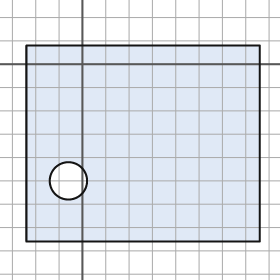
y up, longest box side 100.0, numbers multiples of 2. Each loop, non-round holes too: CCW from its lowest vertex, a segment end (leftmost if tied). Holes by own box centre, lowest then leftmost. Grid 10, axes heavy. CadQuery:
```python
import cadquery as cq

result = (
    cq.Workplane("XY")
    .moveTo(-24.0, -76.0)
    .lineTo(76.0, -76.0)
    .lineTo(76.0, 8.0)
    .lineTo(-24.0, 8.0)
    .close()
    .moveTo(-6.0, -50.0)
    .circle(8.0)
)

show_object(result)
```